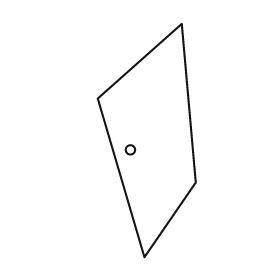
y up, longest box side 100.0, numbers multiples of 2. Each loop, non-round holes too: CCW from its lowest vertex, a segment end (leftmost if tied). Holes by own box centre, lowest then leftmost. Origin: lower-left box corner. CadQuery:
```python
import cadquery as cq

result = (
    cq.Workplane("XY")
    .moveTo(20.0, 0.0)
    .lineTo(42.0, 32.0)
    .lineTo(36.0, 100.0)
    .lineTo(0.0, 68.0)
    .close()
    .moveTo(14.0, 46.0)
    .circle(2.0)
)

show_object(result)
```